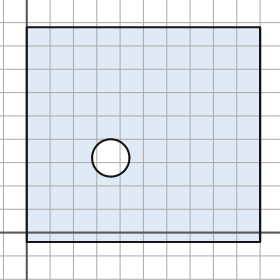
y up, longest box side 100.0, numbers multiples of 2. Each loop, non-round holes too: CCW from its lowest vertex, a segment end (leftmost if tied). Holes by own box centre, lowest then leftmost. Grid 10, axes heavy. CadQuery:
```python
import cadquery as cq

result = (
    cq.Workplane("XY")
    .moveTo(0.0, -4.0)
    .lineTo(100.0, -4.0)
    .lineTo(100.0, 88.0)
    .lineTo(0.0, 88.0)
    .close()
    .moveTo(36.0, 32.0)
    .circle(8.0)
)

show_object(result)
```